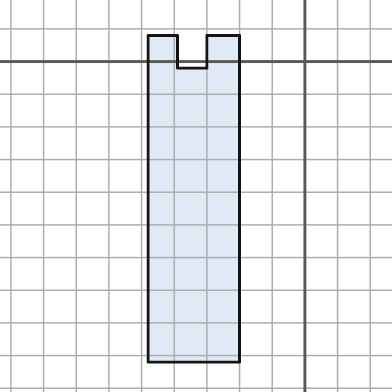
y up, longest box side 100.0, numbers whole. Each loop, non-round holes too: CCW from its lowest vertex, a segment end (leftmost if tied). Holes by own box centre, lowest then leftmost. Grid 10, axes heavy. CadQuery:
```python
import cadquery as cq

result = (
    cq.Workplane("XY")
    .moveTo(-48.0, -92.0)
    .lineTo(-20.0, -92.0)
    .lineTo(-20.0, 8.0)
    .lineTo(-30.0, 8.0)
    .lineTo(-30.0, -2.0)
    .lineTo(-39.0, -2.0)
    .lineTo(-39.0, 8.0)
    .lineTo(-48.0, 8.0)
    .close()
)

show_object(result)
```